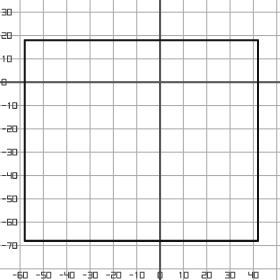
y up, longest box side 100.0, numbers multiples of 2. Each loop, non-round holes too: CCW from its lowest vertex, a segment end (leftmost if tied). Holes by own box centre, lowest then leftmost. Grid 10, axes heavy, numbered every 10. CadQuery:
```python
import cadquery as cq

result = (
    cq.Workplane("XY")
    .moveTo(-58.0, -68.0)
    .lineTo(42.0, -68.0)
    .lineTo(42.0, 18.0)
    .lineTo(-58.0, 18.0)
    .close()
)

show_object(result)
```